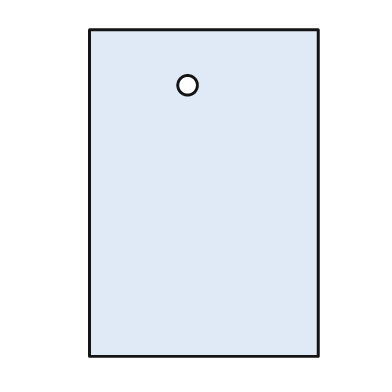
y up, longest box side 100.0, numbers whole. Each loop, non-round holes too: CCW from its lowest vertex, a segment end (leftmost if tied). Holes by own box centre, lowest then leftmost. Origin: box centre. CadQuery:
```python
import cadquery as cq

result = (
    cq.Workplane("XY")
    .moveTo(-35.0, -50.0)
    .lineTo(35.0, -50.0)
    .lineTo(35.0, 50.0)
    .lineTo(-35.0, 50.0)
    .close()
    .moveTo(-5.0, 33.0)
    .circle(3.0)
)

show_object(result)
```